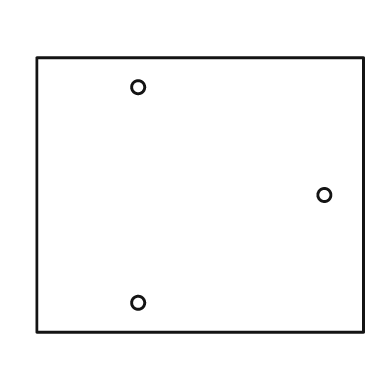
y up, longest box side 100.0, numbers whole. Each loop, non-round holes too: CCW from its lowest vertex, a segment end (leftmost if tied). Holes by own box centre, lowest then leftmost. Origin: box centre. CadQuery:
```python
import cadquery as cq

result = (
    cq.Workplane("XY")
    .moveTo(-50.0, -42.0)
    .lineTo(50.0, -42.0)
    .lineTo(50.0, 42.0)
    .lineTo(-50.0, 42.0)
    .close()
    .moveTo(-19.0, -33.0)
    .circle(2.0)
    .moveTo(38.0, 0.0)
    .circle(2.0)
    .moveTo(-19.0, 33.0)
    .circle(2.0)
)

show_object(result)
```